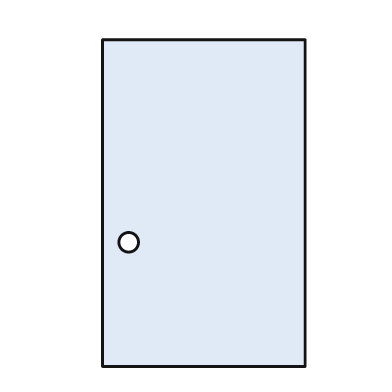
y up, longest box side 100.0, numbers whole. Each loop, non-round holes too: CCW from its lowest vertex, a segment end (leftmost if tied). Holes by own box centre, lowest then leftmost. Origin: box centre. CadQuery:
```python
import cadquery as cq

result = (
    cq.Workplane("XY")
    .moveTo(-31.0, -50.0)
    .lineTo(31.0, -50.0)
    .lineTo(31.0, 50.0)
    .lineTo(-31.0, 50.0)
    .close()
    .moveTo(-23.0, -12.0)
    .circle(3.0)
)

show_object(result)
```